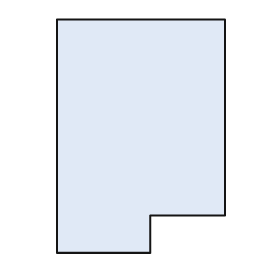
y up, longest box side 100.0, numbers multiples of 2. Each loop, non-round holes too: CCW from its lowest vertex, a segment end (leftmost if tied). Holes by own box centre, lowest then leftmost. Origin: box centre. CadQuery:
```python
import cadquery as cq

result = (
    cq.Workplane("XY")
    .moveTo(-36.0, -50.0)
    .lineTo(4.0, -50.0)
    .lineTo(4.0, -34.0)
    .lineTo(36.0, -34.0)
    .lineTo(36.0, 50.0)
    .lineTo(-36.0, 50.0)
    .close()
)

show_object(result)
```